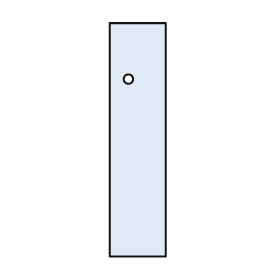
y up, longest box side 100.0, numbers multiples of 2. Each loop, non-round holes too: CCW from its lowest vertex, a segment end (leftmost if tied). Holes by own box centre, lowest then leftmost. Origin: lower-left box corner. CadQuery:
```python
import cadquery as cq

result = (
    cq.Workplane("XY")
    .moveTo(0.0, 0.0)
    .lineTo(24.0, 0.0)
    .lineTo(24.0, 100.0)
    .lineTo(0.0, 100.0)
    .close()
    .moveTo(8.0, 76.0)
    .circle(2.0)
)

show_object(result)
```